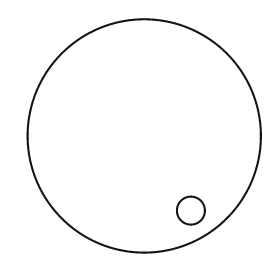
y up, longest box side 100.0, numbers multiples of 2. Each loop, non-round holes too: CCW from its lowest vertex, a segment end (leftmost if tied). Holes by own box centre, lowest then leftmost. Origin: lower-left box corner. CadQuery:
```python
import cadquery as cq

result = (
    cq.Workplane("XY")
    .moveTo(50.0, 50.0)
    .circle(50.0)
    .moveTo(70.0, 18.0)
    .circle(6.0)
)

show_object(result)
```